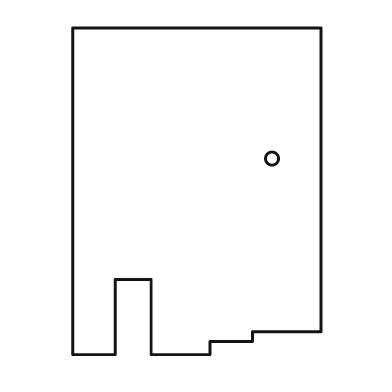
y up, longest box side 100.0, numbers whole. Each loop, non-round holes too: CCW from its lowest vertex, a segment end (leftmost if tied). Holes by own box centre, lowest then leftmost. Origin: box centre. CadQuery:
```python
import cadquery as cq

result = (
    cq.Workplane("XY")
    .moveTo(-38.0, -50.0)
    .lineTo(-25.0, -50.0)
    .lineTo(-25.0, -27.0)
    .lineTo(-14.0, -27.0)
    .lineTo(-14.0, -50.0)
    .lineTo(4.0, -50.0)
    .lineTo(4.0, -46.0)
    .lineTo(17.0, -46.0)
    .lineTo(17.0, -43.0)
    .lineTo(38.0, -43.0)
    .lineTo(38.0, 50.0)
    .lineTo(-38.0, 50.0)
    .close()
    .moveTo(23.0, 10.0)
    .circle(2.0)
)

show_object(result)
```